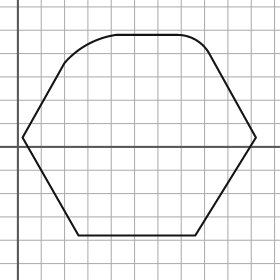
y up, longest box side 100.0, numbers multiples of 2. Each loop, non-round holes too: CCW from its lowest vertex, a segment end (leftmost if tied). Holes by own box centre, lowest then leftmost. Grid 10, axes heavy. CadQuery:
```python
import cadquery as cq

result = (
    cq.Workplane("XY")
    .moveTo(26.0, -38.0)
    .lineTo(76.0, -38.0)
    .lineTo(102.0, 4.0)
    .lineTo(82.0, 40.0)
    .threePointArc((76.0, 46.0), (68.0, 48.0))
    .lineTo(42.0, 48.0)
    .threePointArc((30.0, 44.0), (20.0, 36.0))
    .lineTo(2.0, 4.0)
    .close()
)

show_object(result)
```